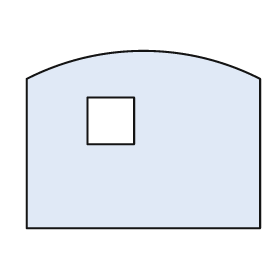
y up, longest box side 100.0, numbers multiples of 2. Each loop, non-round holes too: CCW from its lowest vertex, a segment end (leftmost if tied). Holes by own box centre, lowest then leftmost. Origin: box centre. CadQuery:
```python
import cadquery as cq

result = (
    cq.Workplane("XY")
    .moveTo(-50.0, -38.0)
    .lineTo(50.0, -38.0)
    .lineTo(50.0, 26.0)
    .threePointArc((0.0, 38.0), (-50.0, 26.0))
    .close()
    .moveTo(-24.0, -2.0)
    .lineTo(-4.0, -2.0)
    .lineTo(-4.0, 18.0)
    .lineTo(-24.0, 18.0)
    .close()
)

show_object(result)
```